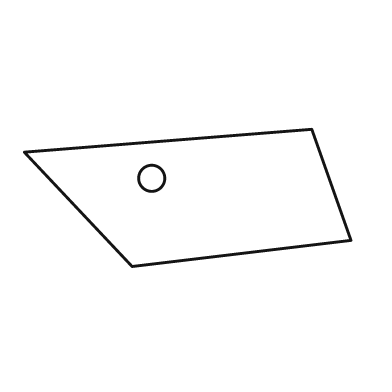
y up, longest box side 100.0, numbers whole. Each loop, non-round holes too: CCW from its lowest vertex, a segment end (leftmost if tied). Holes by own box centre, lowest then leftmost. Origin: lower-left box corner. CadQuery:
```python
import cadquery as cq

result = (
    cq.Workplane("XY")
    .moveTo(33.0, 0.0)
    .lineTo(100.0, 8.0)
    .lineTo(88.0, 42.0)
    .lineTo(0.0, 35.0)
    .close()
    .moveTo(39.0, 27.0)
    .circle(4.0)
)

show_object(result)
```